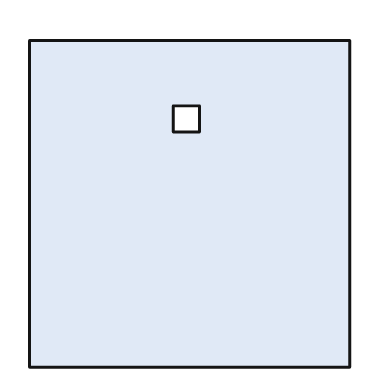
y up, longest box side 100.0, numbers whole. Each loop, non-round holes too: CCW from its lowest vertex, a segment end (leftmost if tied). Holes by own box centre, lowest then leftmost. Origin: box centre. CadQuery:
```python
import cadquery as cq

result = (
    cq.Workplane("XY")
    .moveTo(-49.0, -50.0)
    .lineTo(49.0, -50.0)
    .lineTo(49.0, 50.0)
    .lineTo(-49.0, 50.0)
    .close()
    .moveTo(-5.0, 22.0)
    .lineTo(3.0, 22.0)
    .lineTo(3.0, 30.0)
    .lineTo(-5.0, 30.0)
    .close()
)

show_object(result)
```